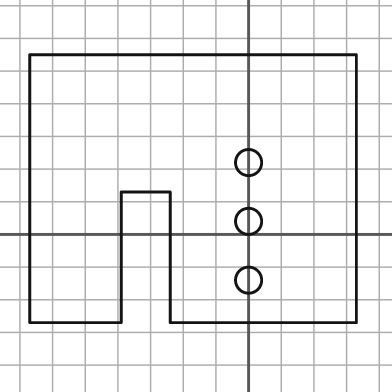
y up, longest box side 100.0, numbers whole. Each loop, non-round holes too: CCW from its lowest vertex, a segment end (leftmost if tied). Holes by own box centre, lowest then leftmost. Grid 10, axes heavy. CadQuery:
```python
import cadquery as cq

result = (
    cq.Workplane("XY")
    .moveTo(-67.0, -27.0)
    .lineTo(-39.0, -27.0)
    .lineTo(-39.0, 13.0)
    .lineTo(-24.0, 13.0)
    .lineTo(-24.0, -27.0)
    .lineTo(33.0, -27.0)
    .lineTo(33.0, 55.0)
    .lineTo(-67.0, 55.0)
    .close()
    .moveTo(0.0, -14.0)
    .circle(4.0)
    .moveTo(0.0, 4.0)
    .circle(4.0)
    .moveTo(0.0, 22.0)
    .circle(4.0)
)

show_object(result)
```